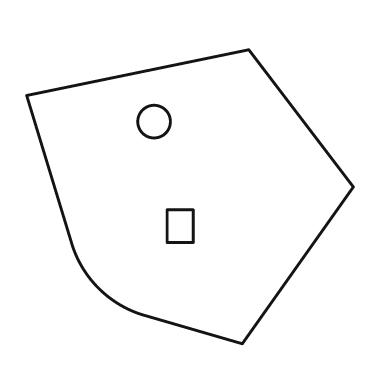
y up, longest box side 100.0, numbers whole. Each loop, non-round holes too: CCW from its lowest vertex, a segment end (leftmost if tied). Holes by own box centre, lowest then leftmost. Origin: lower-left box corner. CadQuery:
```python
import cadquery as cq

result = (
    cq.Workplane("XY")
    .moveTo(66.0, 0.0)
    .lineTo(100.0, 48.0)
    .lineTo(68.0, 90.0)
    .lineTo(0.0, 76.0)
    .lineTo(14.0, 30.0)
    .threePointArc((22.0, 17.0), (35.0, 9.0))
    .close()
    .moveTo(43.0, 31.0)
    .lineTo(51.0, 31.0)
    .lineTo(51.0, 41.0)
    .lineTo(43.0, 41.0)
    .close()
    .moveTo(39.0, 68.0)
    .circle(5.0)
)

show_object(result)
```